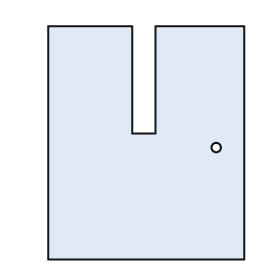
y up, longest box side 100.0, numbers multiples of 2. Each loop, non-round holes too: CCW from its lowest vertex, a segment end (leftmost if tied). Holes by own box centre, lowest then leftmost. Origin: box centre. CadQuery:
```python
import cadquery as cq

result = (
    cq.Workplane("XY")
    .moveTo(-42.0, -50.0)
    .lineTo(42.0, -50.0)
    .lineTo(42.0, 50.0)
    .lineTo(4.0, 50.0)
    .lineTo(4.0, 4.0)
    .lineTo(-6.0, 4.0)
    .lineTo(-6.0, 50.0)
    .lineTo(-42.0, 50.0)
    .close()
    .moveTo(30.0, -2.0)
    .circle(2.0)
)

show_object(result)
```